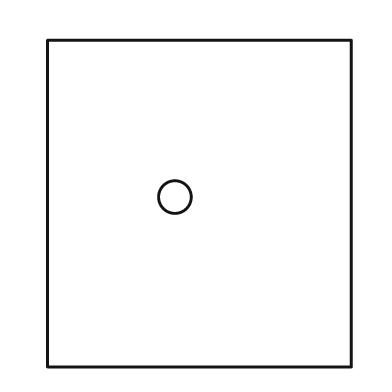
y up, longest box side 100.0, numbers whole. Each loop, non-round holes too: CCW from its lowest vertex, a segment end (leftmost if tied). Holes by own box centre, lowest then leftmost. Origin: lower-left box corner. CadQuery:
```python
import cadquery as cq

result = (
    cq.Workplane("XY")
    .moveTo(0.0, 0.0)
    .lineTo(93.0, 0.0)
    .lineTo(93.0, 100.0)
    .lineTo(0.0, 100.0)
    .close()
    .moveTo(39.0, 52.0)
    .circle(5.0)
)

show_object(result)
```